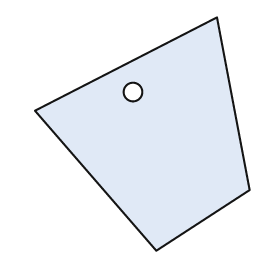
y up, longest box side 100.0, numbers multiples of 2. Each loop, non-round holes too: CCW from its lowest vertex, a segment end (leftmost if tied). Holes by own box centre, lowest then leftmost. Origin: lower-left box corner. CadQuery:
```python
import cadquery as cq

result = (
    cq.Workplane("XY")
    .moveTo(52.0, 0.0)
    .lineTo(92.0, 26.0)
    .lineTo(78.0, 100.0)
    .lineTo(0.0, 60.0)
    .close()
    .moveTo(42.0, 68.0)
    .circle(4.0)
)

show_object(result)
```